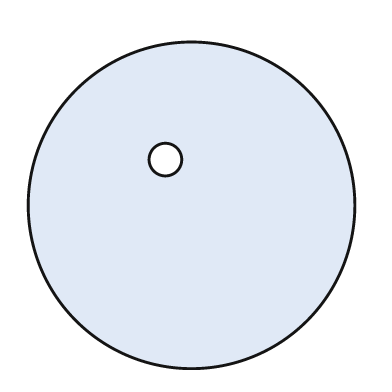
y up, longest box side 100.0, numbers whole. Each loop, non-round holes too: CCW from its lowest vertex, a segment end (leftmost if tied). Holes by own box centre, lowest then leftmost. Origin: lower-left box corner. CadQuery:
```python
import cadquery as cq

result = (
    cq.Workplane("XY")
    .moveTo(50.0, 50.0)
    .circle(50.0)
    .moveTo(42.0, 64.0)
    .circle(5.0)
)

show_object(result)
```